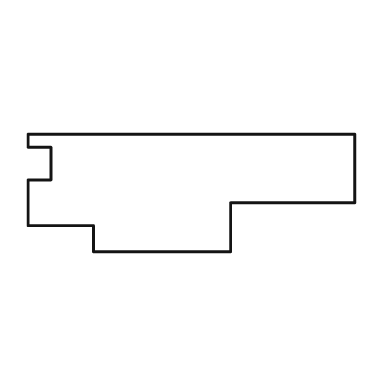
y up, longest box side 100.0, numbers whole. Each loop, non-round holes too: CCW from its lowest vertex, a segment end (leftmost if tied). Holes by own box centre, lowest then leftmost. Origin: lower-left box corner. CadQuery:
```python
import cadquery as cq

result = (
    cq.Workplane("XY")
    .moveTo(20.0, 0.0)
    .lineTo(62.0, 0.0)
    .lineTo(62.0, 15.0)
    .lineTo(100.0, 15.0)
    .lineTo(100.0, 36.0)
    .lineTo(0.0, 36.0)
    .lineTo(0.0, 32.0)
    .lineTo(7.0, 32.0)
    .lineTo(7.0, 22.0)
    .lineTo(0.0, 22.0)
    .lineTo(0.0, 8.0)
    .lineTo(20.0, 8.0)
    .close()
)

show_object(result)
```